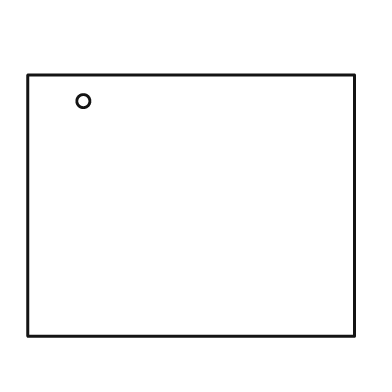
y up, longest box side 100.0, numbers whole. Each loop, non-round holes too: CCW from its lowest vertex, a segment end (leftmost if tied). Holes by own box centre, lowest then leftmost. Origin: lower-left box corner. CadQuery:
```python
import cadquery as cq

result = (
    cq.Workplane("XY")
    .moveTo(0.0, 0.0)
    .lineTo(100.0, 0.0)
    .lineTo(100.0, 80.0)
    .lineTo(0.0, 80.0)
    .close()
    .moveTo(17.0, 72.0)
    .circle(2.0)
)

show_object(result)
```